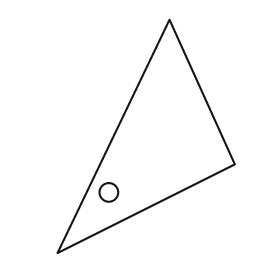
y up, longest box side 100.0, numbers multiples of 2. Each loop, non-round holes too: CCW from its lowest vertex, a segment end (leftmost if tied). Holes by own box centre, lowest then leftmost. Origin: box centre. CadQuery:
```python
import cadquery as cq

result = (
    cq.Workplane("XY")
    .moveTo(-38.0, -50.0)
    .lineTo(38.0, -12.0)
    .lineTo(10.0, 50.0)
    .close()
    .moveTo(-16.0, -24.0)
    .circle(4.0)
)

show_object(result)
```